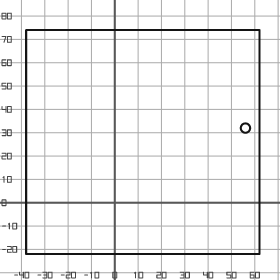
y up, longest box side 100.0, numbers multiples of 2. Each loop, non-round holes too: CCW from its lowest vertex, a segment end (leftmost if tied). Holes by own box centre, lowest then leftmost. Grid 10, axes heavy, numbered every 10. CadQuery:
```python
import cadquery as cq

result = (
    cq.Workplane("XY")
    .moveTo(-38.0, -22.0)
    .lineTo(62.0, -22.0)
    .lineTo(62.0, 74.0)
    .lineTo(-38.0, 74.0)
    .close()
    .moveTo(56.0, 32.0)
    .circle(2.0)
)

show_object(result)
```